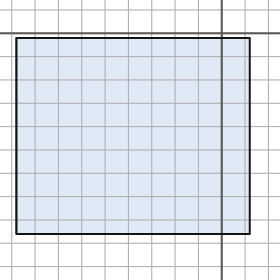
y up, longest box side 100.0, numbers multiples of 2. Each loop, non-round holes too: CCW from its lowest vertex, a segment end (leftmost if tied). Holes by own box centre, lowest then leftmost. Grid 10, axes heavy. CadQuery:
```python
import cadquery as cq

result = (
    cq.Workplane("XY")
    .moveTo(-88.0, -86.0)
    .lineTo(12.0, -86.0)
    .lineTo(12.0, -2.0)
    .lineTo(-88.0, -2.0)
    .close()
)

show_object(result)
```